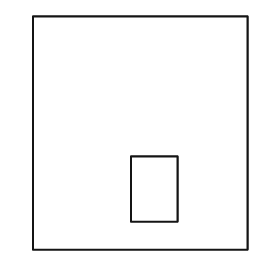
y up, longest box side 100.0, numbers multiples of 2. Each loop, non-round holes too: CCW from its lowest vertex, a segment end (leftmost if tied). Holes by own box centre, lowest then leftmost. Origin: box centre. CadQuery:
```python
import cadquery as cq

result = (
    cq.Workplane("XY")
    .moveTo(-46.0, -50.0)
    .lineTo(46.0, -50.0)
    .lineTo(46.0, 50.0)
    .lineTo(-46.0, 50.0)
    .close()
    .moveTo(-4.0, -38.0)
    .lineTo(16.0, -38.0)
    .lineTo(16.0, -10.0)
    .lineTo(-4.0, -10.0)
    .close()
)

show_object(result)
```